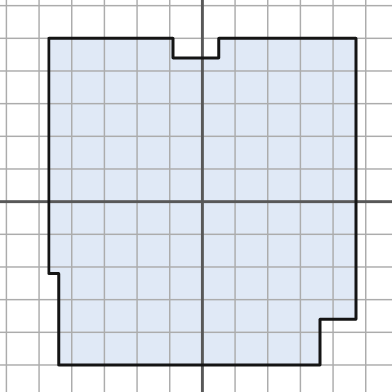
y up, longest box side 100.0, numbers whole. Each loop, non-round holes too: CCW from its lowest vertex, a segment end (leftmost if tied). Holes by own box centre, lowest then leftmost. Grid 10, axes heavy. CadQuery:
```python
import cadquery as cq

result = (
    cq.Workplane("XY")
    .moveTo(-44.0, -50.0)
    .lineTo(36.0, -50.0)
    .lineTo(36.0, -36.0)
    .lineTo(47.0, -36.0)
    .lineTo(47.0, 50.0)
    .lineTo(5.0, 50.0)
    .lineTo(5.0, 44.0)
    .lineTo(-9.0, 44.0)
    .lineTo(-9.0, 50.0)
    .lineTo(-47.0, 50.0)
    .lineTo(-47.0, -22.0)
    .lineTo(-44.0, -22.0)
    .close()
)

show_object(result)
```